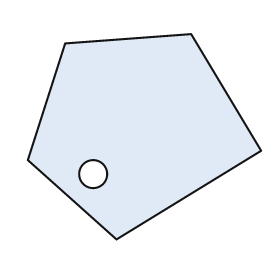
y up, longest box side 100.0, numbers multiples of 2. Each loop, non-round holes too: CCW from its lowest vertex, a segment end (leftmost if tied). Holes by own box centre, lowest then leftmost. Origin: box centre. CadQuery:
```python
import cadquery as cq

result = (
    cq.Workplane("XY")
    .moveTo(-12.0, -44.0)
    .lineTo(50.0, -6.0)
    .lineTo(20.0, 44.0)
    .lineTo(-34.0, 40.0)
    .lineTo(-50.0, -10.0)
    .close()
    .moveTo(-22.0, -16.0)
    .circle(6.0)
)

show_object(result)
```